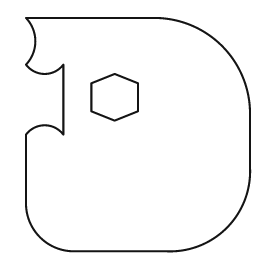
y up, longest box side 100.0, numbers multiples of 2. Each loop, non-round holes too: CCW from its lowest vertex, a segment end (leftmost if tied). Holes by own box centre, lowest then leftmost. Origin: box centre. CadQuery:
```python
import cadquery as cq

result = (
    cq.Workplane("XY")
    .moveTo(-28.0, -50.0)
    .lineTo(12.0, -50.0)
    .threePointArc((38.0, -40.0), (48.0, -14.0))
    .lineTo(48.0, 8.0)
    .threePointArc((36.0, 38.0), (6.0, 50.0))
    .lineTo(-48.0, 50.0)
    .threePointArc((-44.0, 40.0), (-48.0, 30.0))
    .threePointArc((-40.0, 26.0), (-32.0, 30.0))
    .lineTo(-32.0, 0.0)
    .threePointArc((-40.0, 4.0), (-48.0, 0.0))
    .lineTo(-48.0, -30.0)
    .threePointArc((-42.0, -44.0), (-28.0, -50.0))
    .close()
    .moveTo(-10.0, 6.0)
    .lineTo(0.0, 10.0)
    .lineTo(0.0, 22.0)
    .lineTo(-10.0, 26.0)
    .lineTo(-20.0, 22.0)
    .lineTo(-20.0, 10.0)
    .close()
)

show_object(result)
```